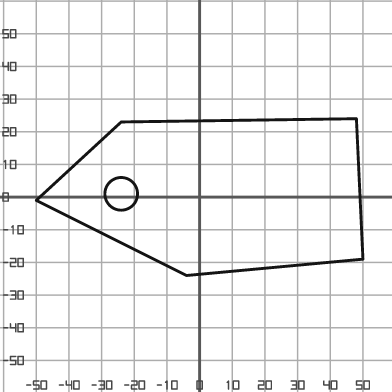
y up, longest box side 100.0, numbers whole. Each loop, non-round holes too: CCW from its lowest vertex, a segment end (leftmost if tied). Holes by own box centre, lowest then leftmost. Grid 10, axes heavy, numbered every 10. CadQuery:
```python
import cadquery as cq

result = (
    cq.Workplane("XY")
    .moveTo(-4.0, -24.0)
    .lineTo(50.0, -19.0)
    .lineTo(48.0, 24.0)
    .lineTo(-24.0, 23.0)
    .lineTo(-50.0, -1.0)
    .close()
    .moveTo(-24.0, 1.0)
    .circle(5.0)
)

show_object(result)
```